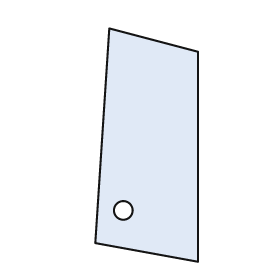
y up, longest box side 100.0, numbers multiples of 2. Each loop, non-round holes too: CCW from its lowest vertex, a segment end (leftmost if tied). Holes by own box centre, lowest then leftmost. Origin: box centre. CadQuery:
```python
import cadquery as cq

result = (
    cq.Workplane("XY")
    .moveTo(22.0, -50.0)
    .lineTo(22.0, 40.0)
    .lineTo(-16.0, 50.0)
    .lineTo(-22.0, -42.0)
    .close()
    .moveTo(-10.0, -28.0)
    .circle(4.0)
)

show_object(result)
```